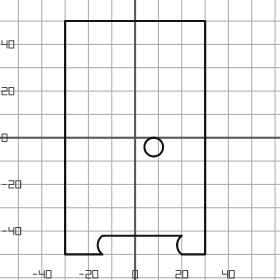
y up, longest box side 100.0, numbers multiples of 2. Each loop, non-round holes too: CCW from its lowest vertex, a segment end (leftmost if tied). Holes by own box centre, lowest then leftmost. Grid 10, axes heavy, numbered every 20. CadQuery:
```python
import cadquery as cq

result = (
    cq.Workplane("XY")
    .moveTo(-30.0, -50.0)
    .lineTo(-14.0, -50.0)
    .threePointArc((-16.0, -46.0), (-14.0, -42.0))
    .lineTo(20.0, -42.0)
    .threePointArc((18.0, -46.0), (20.0, -50.0))
    .lineTo(30.0, -50.0)
    .lineTo(30.0, 50.0)
    .lineTo(-30.0, 50.0)
    .close()
    .moveTo(8.0, -4.0)
    .circle(4.0)
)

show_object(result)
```